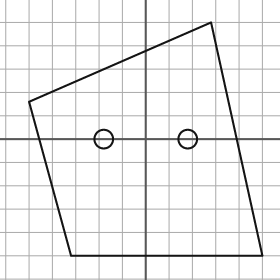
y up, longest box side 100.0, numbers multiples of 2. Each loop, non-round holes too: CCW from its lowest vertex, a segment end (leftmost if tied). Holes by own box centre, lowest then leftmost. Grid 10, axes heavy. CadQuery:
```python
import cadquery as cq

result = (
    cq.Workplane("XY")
    .moveTo(-32.0, -50.0)
    .lineTo(50.0, -50.0)
    .lineTo(28.0, 50.0)
    .lineTo(-50.0, 16.0)
    .close()
    .moveTo(-18.0, 0.0)
    .circle(4.0)
    .moveTo(18.0, 0.0)
    .circle(4.0)
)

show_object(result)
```